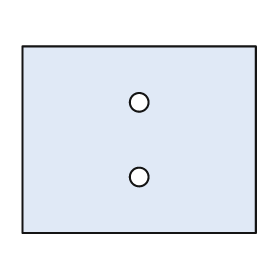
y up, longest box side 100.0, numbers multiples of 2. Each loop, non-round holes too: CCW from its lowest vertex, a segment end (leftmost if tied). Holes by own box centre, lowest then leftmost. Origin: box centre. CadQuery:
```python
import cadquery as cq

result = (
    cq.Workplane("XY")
    .moveTo(-50.0, -40.0)
    .lineTo(50.0, -40.0)
    .lineTo(50.0, 40.0)
    .lineTo(-50.0, 40.0)
    .close()
    .moveTo(0.0, -16.0)
    .circle(4.0)
    .moveTo(0.0, 16.0)
    .circle(4.0)
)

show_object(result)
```